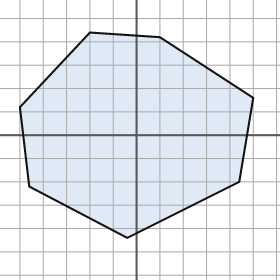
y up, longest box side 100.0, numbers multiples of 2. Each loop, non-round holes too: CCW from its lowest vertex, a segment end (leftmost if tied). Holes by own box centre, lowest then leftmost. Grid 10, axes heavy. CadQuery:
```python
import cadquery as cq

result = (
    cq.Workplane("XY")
    .moveTo(-4.0, -44.0)
    .lineTo(44.0, -20.0)
    .lineTo(50.0, 16.0)
    .lineTo(10.0, 42.0)
    .lineTo(-20.0, 44.0)
    .lineTo(-50.0, 12.0)
    .lineTo(-46.0, -22.0)
    .close()
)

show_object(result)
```